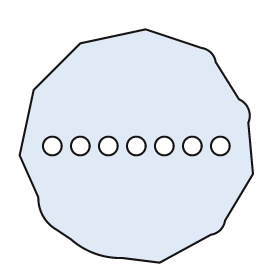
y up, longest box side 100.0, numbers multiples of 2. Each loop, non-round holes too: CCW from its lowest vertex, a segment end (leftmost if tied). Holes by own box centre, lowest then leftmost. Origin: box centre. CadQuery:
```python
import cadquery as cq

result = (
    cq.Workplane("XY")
    .moveTo(10.0, -50.0)
    .lineTo(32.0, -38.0)
    .threePointArc((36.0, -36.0), (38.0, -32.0))
    .lineTo(50.0, -12.0)
    .lineTo(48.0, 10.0)
    .threePointArc((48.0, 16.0), (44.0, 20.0))
    .lineTo(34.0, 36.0)
    .threePointArc((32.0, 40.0), (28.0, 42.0))
    .lineTo(4.0, 50.0)
    .lineTo(-24.0, 44.0)
    .lineTo(-44.0, 24.0)
    .lineTo(-50.0, -4.0)
    .lineTo(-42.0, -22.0)
    .threePointArc((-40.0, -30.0), (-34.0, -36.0))
    .lineTo(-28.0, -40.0)
    .threePointArc((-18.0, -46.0), (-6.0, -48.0))
    .close()
    .moveTo(-36.0, 0.0)
    .circle(4.0)
    .moveTo(-24.0, 0.0)
    .circle(4.0)
    .moveTo(-12.0, 0.0)
    .circle(4.0)
    .moveTo(0.0, 0.0)
    .circle(4.0)
    .moveTo(12.0, 0.0)
    .circle(4.0)
    .moveTo(24.0, 0.0)
    .circle(4.0)
    .moveTo(36.0, 0.0)
    .circle(4.0)
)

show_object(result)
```